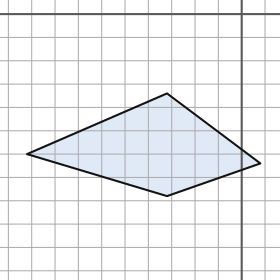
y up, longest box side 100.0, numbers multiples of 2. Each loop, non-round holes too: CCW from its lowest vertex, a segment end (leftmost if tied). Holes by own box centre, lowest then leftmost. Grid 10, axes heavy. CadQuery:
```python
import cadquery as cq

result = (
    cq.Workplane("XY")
    .moveTo(-32.0, -78.0)
    .lineTo(8.0, -64.0)
    .lineTo(-32.0, -34.0)
    .lineTo(-92.0, -60.0)
    .close()
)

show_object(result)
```